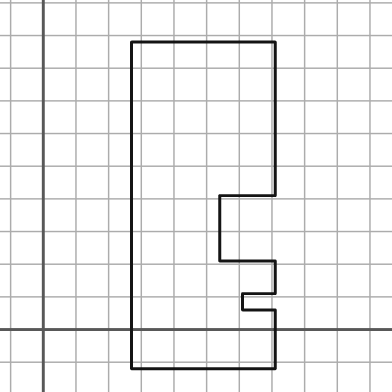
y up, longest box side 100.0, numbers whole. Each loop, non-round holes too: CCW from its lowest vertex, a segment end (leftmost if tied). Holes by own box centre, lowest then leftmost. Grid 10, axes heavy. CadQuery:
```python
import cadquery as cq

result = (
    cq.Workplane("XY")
    .moveTo(27.0, -12.0)
    .lineTo(71.0, -12.0)
    .lineTo(71.0, 6.0)
    .lineTo(61.0, 6.0)
    .lineTo(61.0, 11.0)
    .lineTo(71.0, 11.0)
    .lineTo(71.0, 21.0)
    .lineTo(54.0, 21.0)
    .lineTo(54.0, 41.0)
    .lineTo(71.0, 41.0)
    .lineTo(71.0, 88.0)
    .lineTo(27.0, 88.0)
    .close()
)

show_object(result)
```